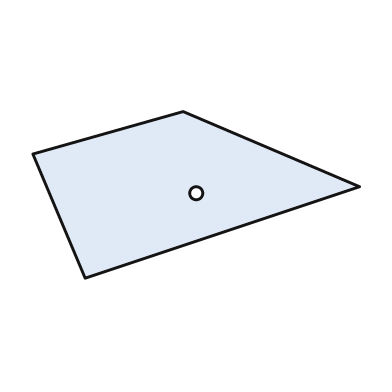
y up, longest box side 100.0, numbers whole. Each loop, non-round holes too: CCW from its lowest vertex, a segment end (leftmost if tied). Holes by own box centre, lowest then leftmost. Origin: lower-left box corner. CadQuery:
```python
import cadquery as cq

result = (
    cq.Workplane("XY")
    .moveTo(16.0, 0.0)
    .lineTo(100.0, 28.0)
    .lineTo(46.0, 51.0)
    .lineTo(0.0, 38.0)
    .close()
    .moveTo(50.0, 26.0)
    .circle(2.0)
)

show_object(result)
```